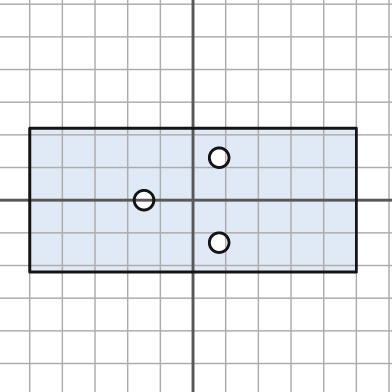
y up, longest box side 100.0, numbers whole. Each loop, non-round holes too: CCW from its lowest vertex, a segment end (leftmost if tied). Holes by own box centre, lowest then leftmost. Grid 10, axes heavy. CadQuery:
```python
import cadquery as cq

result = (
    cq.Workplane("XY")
    .moveTo(-50.0, -22.0)
    .lineTo(50.0, -22.0)
    .lineTo(50.0, 22.0)
    .lineTo(-50.0, 22.0)
    .close()
    .moveTo(8.0, -13.0)
    .circle(3.0)
    .moveTo(-15.0, 0.0)
    .circle(3.0)
    .moveTo(8.0, 13.0)
    .circle(3.0)
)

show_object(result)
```